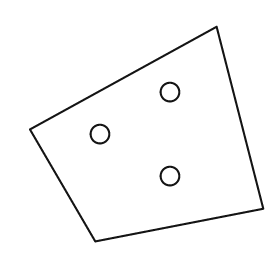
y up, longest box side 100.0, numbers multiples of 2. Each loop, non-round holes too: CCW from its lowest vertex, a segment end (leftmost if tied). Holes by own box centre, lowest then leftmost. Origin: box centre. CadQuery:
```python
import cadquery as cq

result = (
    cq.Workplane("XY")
    .moveTo(-22.0, -46.0)
    .lineTo(50.0, -32.0)
    .lineTo(30.0, 46.0)
    .lineTo(-50.0, 2.0)
    .close()
    .moveTo(10.0, -18.0)
    .circle(4.0)
    .moveTo(-20.0, 0.0)
    .circle(4.0)
    .moveTo(10.0, 18.0)
    .circle(4.0)
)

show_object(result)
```